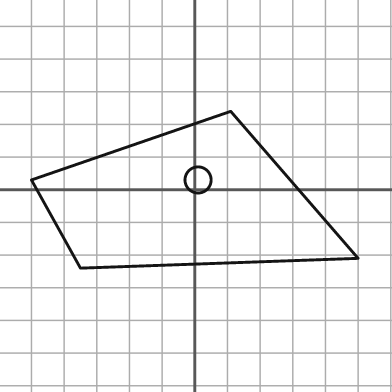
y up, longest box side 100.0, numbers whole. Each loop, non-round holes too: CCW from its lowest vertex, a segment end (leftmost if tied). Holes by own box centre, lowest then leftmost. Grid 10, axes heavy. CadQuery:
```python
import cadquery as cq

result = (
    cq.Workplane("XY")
    .moveTo(-35.0, -24.0)
    .lineTo(50.0, -21.0)
    .lineTo(11.0, 24.0)
    .lineTo(-50.0, 3.0)
    .close()
    .moveTo(1.0, 3.0)
    .circle(4.0)
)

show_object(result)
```